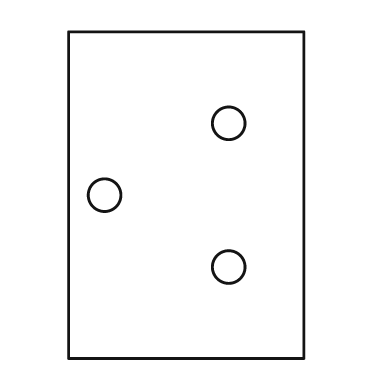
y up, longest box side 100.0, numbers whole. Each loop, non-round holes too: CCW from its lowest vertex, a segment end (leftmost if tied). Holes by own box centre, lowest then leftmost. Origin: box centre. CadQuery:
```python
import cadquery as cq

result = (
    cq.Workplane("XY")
    .moveTo(-36.0, -50.0)
    .lineTo(36.0, -50.0)
    .lineTo(36.0, 50.0)
    .lineTo(-36.0, 50.0)
    .close()
    .moveTo(13.0, -22.0)
    .circle(5.0)
    .moveTo(-25.0, 0.0)
    .circle(5.0)
    .moveTo(13.0, 22.0)
    .circle(5.0)
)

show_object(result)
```